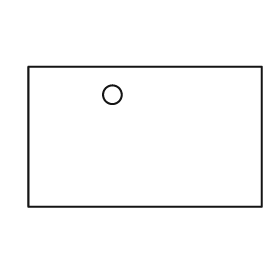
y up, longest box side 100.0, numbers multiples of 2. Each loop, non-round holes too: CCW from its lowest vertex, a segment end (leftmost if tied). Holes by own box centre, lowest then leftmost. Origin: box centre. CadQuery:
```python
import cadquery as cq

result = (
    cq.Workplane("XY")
    .moveTo(-50.0, -30.0)
    .lineTo(50.0, -30.0)
    .lineTo(50.0, 30.0)
    .lineTo(-50.0, 30.0)
    .close()
    .moveTo(-14.0, 18.0)
    .circle(4.0)
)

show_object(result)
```